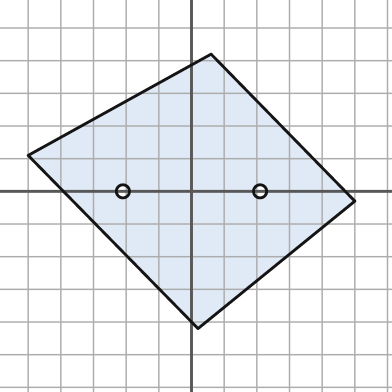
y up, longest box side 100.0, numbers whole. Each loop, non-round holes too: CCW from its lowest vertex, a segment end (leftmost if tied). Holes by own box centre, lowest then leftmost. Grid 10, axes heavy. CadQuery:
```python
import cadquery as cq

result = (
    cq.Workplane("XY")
    .moveTo(2.0, -42.0)
    .lineTo(50.0, -3.0)
    .lineTo(6.0, 42.0)
    .lineTo(-50.0, 11.0)
    .close()
    .moveTo(-21.0, 0.0)
    .circle(2.0)
    .moveTo(21.0, 0.0)
    .circle(2.0)
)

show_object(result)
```